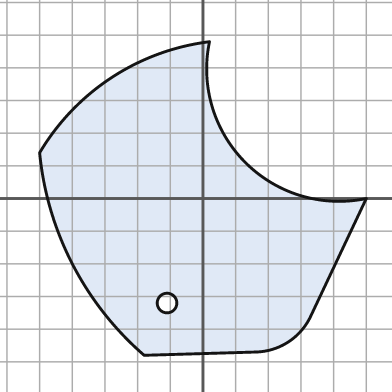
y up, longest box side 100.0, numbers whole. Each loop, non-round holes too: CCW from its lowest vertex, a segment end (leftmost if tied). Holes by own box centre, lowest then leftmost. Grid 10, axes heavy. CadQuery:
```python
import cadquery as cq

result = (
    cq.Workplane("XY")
    .moveTo(-18.0, -48.0)
    .lineTo(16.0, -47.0)
    .threePointArc((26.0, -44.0), (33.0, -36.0))
    .lineTo(50.0, 0.0)
    .threePointArc((13.0, 11.0), (2.0, 48.0))
    .threePointArc((-28.0, 37.0), (-50.0, 14.0))
    .threePointArc((-40.0, -20.0), (-18.0, -48.0))
    .close()
    .moveTo(-11.0, -32.0)
    .circle(3.0)
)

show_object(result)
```